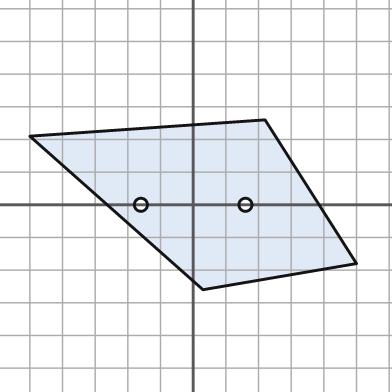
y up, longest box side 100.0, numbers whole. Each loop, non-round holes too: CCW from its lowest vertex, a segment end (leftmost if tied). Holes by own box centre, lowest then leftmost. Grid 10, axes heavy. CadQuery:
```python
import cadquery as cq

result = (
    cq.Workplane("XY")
    .moveTo(3.0, -26.0)
    .lineTo(50.0, -18.0)
    .lineTo(22.0, 26.0)
    .lineTo(-50.0, 21.0)
    .close()
    .moveTo(-16.0, 0.0)
    .circle(2.0)
    .moveTo(16.0, 0.0)
    .circle(2.0)
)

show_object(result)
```